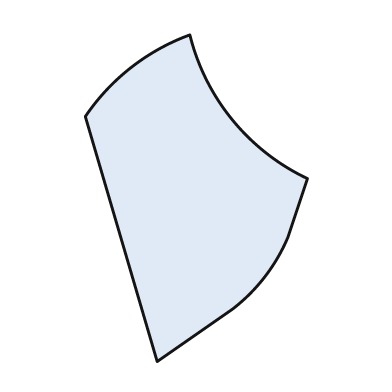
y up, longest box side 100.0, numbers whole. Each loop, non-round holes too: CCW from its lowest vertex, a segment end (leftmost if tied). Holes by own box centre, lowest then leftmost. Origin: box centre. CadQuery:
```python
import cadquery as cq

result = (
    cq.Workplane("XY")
    .moveTo(-12.0, -50.0)
    .lineTo(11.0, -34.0)
    .threePointArc((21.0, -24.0), (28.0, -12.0))
    .lineTo(34.0, 6.0)
    .threePointArc((11.0, 24.0), (-2.0, 50.0))
    .threePointArc((-20.0, 40.0), (-34.0, 25.0))
    .close()
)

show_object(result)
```